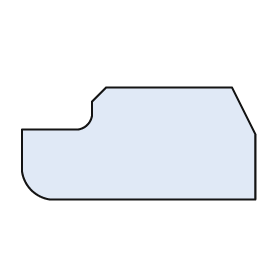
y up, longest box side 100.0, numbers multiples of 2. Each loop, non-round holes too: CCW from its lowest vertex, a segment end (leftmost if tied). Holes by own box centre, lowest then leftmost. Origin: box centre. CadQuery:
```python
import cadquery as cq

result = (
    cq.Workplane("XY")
    .moveTo(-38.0, -24.0)
    .lineTo(50.0, -24.0)
    .lineTo(50.0, 4.0)
    .lineTo(40.0, 24.0)
    .lineTo(-14.0, 24.0)
    .lineTo(-20.0, 18.0)
    .lineTo(-20.0, 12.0)
    .threePointArc((-22.0, 8.0), (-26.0, 6.0))
    .lineTo(-50.0, 6.0)
    .lineTo(-50.0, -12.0)
    .threePointArc((-46.0, -20.0), (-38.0, -24.0))
    .close()
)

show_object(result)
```